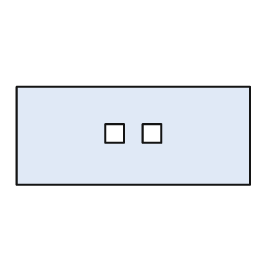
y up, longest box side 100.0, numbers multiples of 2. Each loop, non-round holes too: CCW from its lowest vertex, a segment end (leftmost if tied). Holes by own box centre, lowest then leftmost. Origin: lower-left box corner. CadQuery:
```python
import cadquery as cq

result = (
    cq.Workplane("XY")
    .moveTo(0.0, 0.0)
    .lineTo(100.0, 0.0)
    .lineTo(100.0, 42.0)
    .lineTo(0.0, 42.0)
    .close()
    .moveTo(38.0, 18.0)
    .lineTo(46.0, 18.0)
    .lineTo(46.0, 26.0)
    .lineTo(38.0, 26.0)
    .close()
    .moveTo(54.0, 18.0)
    .lineTo(62.0, 18.0)
    .lineTo(62.0, 26.0)
    .lineTo(54.0, 26.0)
    .close()
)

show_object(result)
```